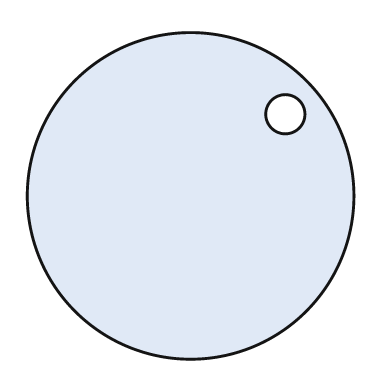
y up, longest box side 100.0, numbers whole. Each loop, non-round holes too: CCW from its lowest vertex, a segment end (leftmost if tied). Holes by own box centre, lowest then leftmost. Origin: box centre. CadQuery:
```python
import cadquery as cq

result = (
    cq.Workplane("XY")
    .moveTo(0.0, 0.0)
    .circle(50.0)
    .moveTo(29.0, 25.0)
    .circle(6.0)
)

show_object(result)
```